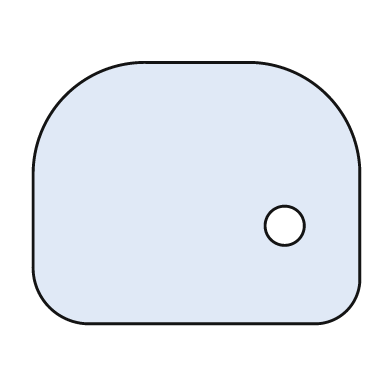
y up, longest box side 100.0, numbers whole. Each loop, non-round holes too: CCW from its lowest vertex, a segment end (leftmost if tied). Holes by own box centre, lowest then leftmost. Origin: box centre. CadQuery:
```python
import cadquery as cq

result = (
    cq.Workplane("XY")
    .moveTo(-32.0, -40.0)
    .lineTo(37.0, -40.0)
    .threePointArc((46.0, -36.0), (50.0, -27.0))
    .lineTo(50.0, 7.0)
    .threePointArc((40.0, 30.0), (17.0, 40.0))
    .lineTo(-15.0, 40.0)
    .threePointArc((-40.0, 30.0), (-50.0, 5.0))
    .lineTo(-50.0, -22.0)
    .threePointArc((-45.0, -35.0), (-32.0, -40.0))
    .close()
    .moveTo(27.0, -10.0)
    .circle(6.0)
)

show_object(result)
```